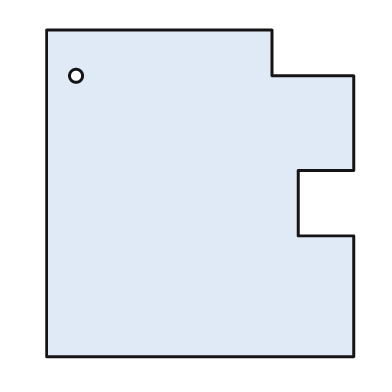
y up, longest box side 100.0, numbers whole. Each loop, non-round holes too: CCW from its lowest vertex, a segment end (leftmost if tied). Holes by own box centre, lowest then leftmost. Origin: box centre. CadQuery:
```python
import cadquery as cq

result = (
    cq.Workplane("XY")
    .moveTo(-47.0, -50.0)
    .lineTo(47.0, -50.0)
    .lineTo(47.0, -13.0)
    .lineTo(30.0, -13.0)
    .lineTo(30.0, 7.0)
    .lineTo(47.0, 7.0)
    .lineTo(47.0, 36.0)
    .lineTo(22.0, 36.0)
    .lineTo(22.0, 50.0)
    .lineTo(-47.0, 50.0)
    .close()
    .moveTo(-38.0, 36.0)
    .circle(2.0)
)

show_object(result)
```